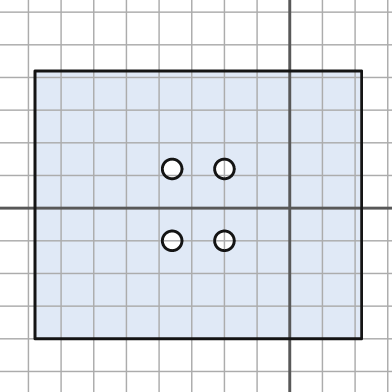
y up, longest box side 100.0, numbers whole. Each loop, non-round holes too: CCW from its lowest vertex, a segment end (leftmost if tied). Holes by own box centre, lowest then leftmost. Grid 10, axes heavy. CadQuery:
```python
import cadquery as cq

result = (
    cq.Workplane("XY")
    .moveTo(-78.0, -40.0)
    .lineTo(22.0, -40.0)
    .lineTo(22.0, 42.0)
    .lineTo(-78.0, 42.0)
    .close()
    .moveTo(-36.0, -10.0)
    .circle(3.0)
    .moveTo(-20.0, -10.0)
    .circle(3.0)
    .moveTo(-36.0, 12.0)
    .circle(3.0)
    .moveTo(-20.0, 12.0)
    .circle(3.0)
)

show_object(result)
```